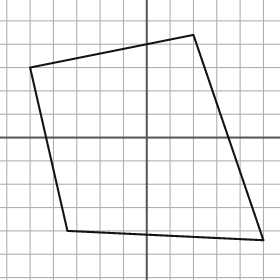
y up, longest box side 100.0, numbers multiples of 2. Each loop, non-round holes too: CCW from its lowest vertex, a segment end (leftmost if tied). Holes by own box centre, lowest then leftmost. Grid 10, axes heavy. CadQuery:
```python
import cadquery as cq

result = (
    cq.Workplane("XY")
    .moveTo(50.0, -44.0)
    .lineTo(20.0, 44.0)
    .lineTo(-50.0, 30.0)
    .lineTo(-34.0, -40.0)
    .close()
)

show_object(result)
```